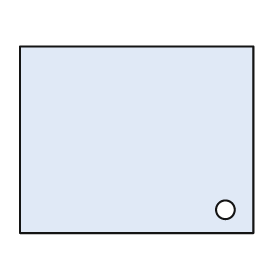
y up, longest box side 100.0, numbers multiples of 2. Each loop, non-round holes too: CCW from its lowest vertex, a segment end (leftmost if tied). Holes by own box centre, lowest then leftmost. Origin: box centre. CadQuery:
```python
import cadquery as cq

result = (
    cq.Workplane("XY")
    .moveTo(-50.0, -40.0)
    .lineTo(50.0, -40.0)
    .lineTo(50.0, 40.0)
    .lineTo(-50.0, 40.0)
    .close()
    .moveTo(38.0, -30.0)
    .circle(4.0)
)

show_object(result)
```